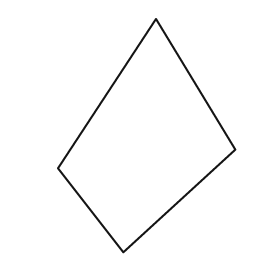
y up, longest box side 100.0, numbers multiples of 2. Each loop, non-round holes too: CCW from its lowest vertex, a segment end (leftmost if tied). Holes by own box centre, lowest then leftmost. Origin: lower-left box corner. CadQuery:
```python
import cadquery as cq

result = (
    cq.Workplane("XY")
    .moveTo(28.0, 0.0)
    .lineTo(76.0, 44.0)
    .lineTo(42.0, 100.0)
    .lineTo(0.0, 36.0)
    .close()
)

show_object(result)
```